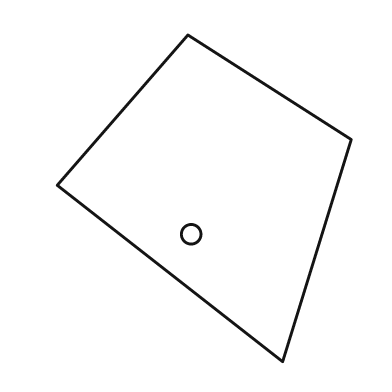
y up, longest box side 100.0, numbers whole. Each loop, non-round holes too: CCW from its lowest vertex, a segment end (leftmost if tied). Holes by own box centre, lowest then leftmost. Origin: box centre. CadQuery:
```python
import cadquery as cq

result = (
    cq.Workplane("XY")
    .moveTo(24.0, -50.0)
    .lineTo(45.0, 18.0)
    .lineTo(-5.0, 50.0)
    .lineTo(-45.0, 4.0)
    .close()
    .moveTo(-4.0, -11.0)
    .circle(3.0)
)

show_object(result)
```